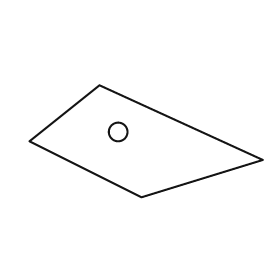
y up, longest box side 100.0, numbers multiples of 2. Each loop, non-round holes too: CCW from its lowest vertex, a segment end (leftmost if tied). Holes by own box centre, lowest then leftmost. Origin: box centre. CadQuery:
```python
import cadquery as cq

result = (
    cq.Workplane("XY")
    .moveTo(-2.0, -24.0)
    .lineTo(50.0, -8.0)
    .lineTo(-20.0, 24.0)
    .lineTo(-50.0, 0.0)
    .close()
    .moveTo(-12.0, 4.0)
    .circle(4.0)
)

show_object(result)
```